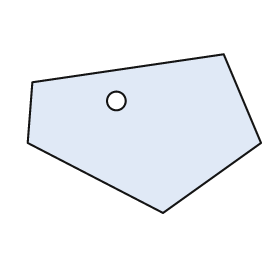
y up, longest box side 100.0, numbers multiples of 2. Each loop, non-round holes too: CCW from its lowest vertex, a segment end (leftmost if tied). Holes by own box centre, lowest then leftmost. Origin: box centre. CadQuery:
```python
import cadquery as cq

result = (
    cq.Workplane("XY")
    .moveTo(8.0, -34.0)
    .lineTo(50.0, -4.0)
    .lineTo(34.0, 34.0)
    .lineTo(-48.0, 22.0)
    .lineTo(-50.0, -4.0)
    .close()
    .moveTo(-12.0, 14.0)
    .circle(4.0)
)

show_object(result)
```